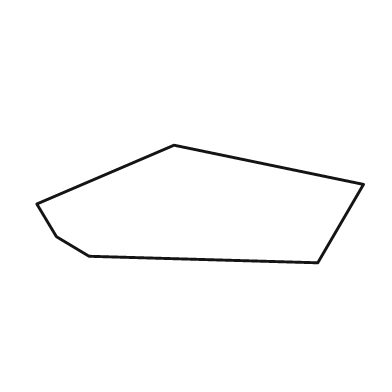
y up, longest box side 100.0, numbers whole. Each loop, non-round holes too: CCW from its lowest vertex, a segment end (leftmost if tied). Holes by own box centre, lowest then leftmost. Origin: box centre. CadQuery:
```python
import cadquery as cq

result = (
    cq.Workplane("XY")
    .moveTo(36.0, -18.0)
    .lineTo(50.0, 6.0)
    .lineTo(-8.0, 18.0)
    .lineTo(-50.0, 0.0)
    .lineTo(-44.0, -10.0)
    .lineTo(-34.0, -16.0)
    .close()
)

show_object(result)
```